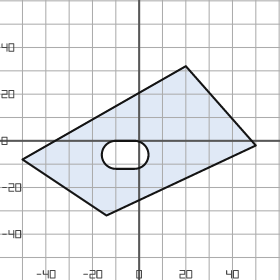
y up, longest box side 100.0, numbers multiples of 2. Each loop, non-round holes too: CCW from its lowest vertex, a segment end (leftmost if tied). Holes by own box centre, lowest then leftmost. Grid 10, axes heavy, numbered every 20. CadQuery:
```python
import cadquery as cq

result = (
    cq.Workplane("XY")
    .moveTo(-14.0, -32.0)
    .lineTo(50.0, -2.0)
    .lineTo(20.0, 32.0)
    .lineTo(-50.0, -8.0)
    .close()
    .moveTo(-10.0, -12.0)
    .lineTo(-2.0, -12.0)
    .threePointArc((4.0, -6.0), (-2.0, 0.0))
    .lineTo(-10.0, 0.0)
    .threePointArc((-16.0, -6.0), (-10.0, -12.0))
    .close()
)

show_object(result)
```